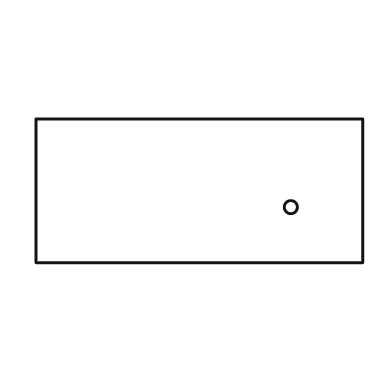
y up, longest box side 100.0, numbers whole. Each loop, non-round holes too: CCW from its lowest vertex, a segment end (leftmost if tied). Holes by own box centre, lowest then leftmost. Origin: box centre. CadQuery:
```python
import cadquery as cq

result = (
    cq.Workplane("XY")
    .moveTo(-50.0, -22.0)
    .lineTo(50.0, -22.0)
    .lineTo(50.0, 22.0)
    .lineTo(-50.0, 22.0)
    .close()
    .moveTo(28.0, -5.0)
    .circle(2.0)
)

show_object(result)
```